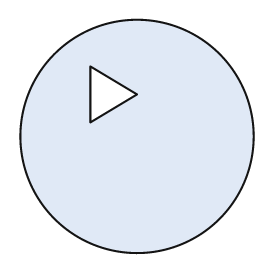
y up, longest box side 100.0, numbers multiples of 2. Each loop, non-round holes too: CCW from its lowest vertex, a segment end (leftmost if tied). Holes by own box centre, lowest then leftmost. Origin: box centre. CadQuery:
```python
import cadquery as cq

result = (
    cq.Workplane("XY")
    .moveTo(0.0, 0.0)
    .circle(50.0)
    .moveTo(-20.0, 6.0)
    .lineTo(0.0, 18.0)
    .lineTo(-20.0, 30.0)
    .close()
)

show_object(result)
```